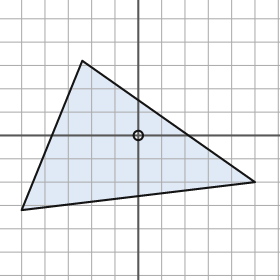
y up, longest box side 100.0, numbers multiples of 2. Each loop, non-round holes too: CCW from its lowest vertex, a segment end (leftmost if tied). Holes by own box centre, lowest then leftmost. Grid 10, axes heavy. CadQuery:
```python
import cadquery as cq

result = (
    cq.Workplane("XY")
    .moveTo(-50.0, -32.0)
    .lineTo(50.0, -20.0)
    .lineTo(-24.0, 32.0)
    .close()
    .moveTo(0.0, 0.0)
    .circle(2.0)
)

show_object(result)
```